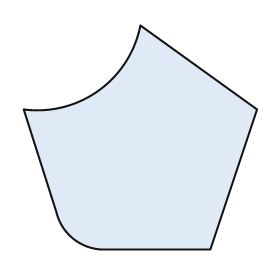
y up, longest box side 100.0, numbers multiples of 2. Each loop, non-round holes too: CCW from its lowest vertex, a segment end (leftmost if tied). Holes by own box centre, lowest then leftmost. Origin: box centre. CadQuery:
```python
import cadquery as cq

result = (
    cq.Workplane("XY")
    .moveTo(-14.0, -48.0)
    .lineTo(30.0, -48.0)
    .lineTo(50.0, 12.0)
    .lineTo(0.0, 48.0)
    .threePointArc((-18.0, 20.0), (-50.0, 12.0))
    .lineTo(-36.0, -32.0)
    .threePointArc((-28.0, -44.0), (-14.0, -48.0))
    .close()
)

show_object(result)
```